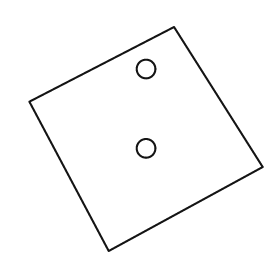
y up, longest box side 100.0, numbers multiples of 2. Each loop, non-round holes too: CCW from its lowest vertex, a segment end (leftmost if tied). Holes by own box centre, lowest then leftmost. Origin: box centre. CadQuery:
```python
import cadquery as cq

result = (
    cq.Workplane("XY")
    .moveTo(-16.0, -48.0)
    .lineTo(50.0, -12.0)
    .lineTo(12.0, 48.0)
    .lineTo(-50.0, 16.0)
    .close()
    .moveTo(0.0, -4.0)
    .circle(4.0)
    .moveTo(0.0, 30.0)
    .circle(4.0)
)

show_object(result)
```